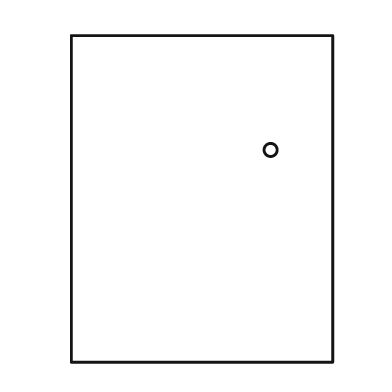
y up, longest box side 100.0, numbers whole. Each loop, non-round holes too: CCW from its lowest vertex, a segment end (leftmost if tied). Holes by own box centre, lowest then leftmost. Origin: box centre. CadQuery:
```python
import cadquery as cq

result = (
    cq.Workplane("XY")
    .moveTo(-40.0, -50.0)
    .lineTo(40.0, -50.0)
    .lineTo(40.0, 50.0)
    .lineTo(-40.0, 50.0)
    .close()
    .moveTo(21.0, 15.0)
    .circle(2.0)
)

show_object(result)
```